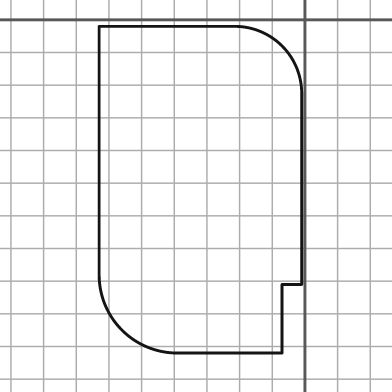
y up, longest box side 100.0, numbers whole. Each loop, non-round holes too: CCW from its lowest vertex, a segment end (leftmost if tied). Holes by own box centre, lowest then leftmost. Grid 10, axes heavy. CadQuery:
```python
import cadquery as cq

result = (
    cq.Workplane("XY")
    .moveTo(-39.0, -102.0)
    .lineTo(-7.0, -102.0)
    .lineTo(-7.0, -81.0)
    .lineTo(-1.0, -81.0)
    .lineTo(-1.0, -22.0)
    .threePointArc((-7.0, -8.0), (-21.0, -2.0))
    .lineTo(-63.0, -2.0)
    .lineTo(-63.0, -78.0)
    .threePointArc((-56.0, -95.0), (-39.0, -102.0))
    .close()
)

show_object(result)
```